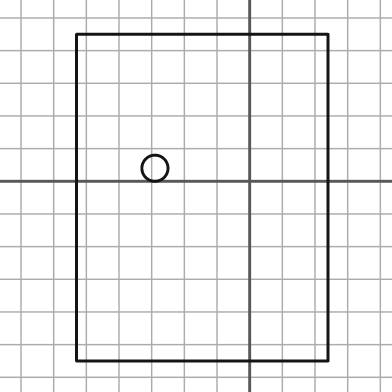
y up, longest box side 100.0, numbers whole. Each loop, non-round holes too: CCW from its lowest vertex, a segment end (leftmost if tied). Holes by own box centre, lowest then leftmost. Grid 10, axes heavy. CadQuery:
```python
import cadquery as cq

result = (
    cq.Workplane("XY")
    .moveTo(-53.0, -55.0)
    .lineTo(24.0, -55.0)
    .lineTo(24.0, 45.0)
    .lineTo(-53.0, 45.0)
    .close()
    .moveTo(-29.0, 4.0)
    .circle(4.0)
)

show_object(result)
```